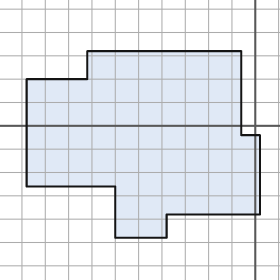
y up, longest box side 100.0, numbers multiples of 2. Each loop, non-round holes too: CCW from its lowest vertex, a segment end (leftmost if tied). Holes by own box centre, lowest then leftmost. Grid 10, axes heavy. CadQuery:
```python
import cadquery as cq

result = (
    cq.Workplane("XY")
    .moveTo(-60.0, -48.0)
    .lineTo(-38.0, -48.0)
    .lineTo(-38.0, -38.0)
    .lineTo(2.0, -38.0)
    .lineTo(2.0, -4.0)
    .lineTo(-6.0, -4.0)
    .lineTo(-6.0, 32.0)
    .lineTo(-72.0, 32.0)
    .lineTo(-72.0, 20.0)
    .lineTo(-98.0, 20.0)
    .lineTo(-98.0, -26.0)
    .lineTo(-60.0, -26.0)
    .close()
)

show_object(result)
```